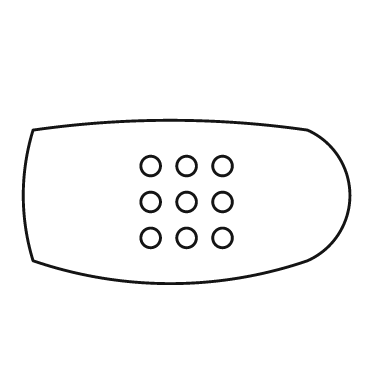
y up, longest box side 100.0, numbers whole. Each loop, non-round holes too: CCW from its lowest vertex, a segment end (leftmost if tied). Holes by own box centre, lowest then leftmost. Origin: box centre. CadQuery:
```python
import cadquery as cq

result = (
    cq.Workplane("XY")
    .moveTo(-47.0, -18.0)
    .threePointArc((-5.0, -25.0), (37.0, -18.0))
    .threePointArc((50.0, 2.0), (37.0, 22.0))
    .threePointArc((-5.0, 25.0), (-47.0, 22.0))
    .threePointArc((-50.0, 2.0), (-47.0, -18.0))
    .close()
    .moveTo(-11.0, -11.0)
    .circle(3.0)
    .moveTo(0.0, -11.0)
    .circle(3.0)
    .moveTo(11.0, -11.0)
    .circle(3.0)
    .moveTo(-11.0, 0.0)
    .circle(3.0)
    .moveTo(0.0, 0.0)
    .circle(3.0)
    .moveTo(11.0, 0.0)
    .circle(3.0)
    .moveTo(-11.0, 11.0)
    .circle(3.0)
    .moveTo(0.0, 11.0)
    .circle(3.0)
    .moveTo(11.0, 11.0)
    .circle(3.0)
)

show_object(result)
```